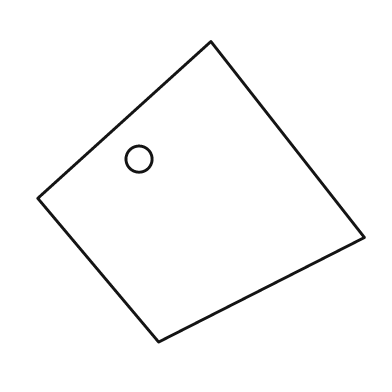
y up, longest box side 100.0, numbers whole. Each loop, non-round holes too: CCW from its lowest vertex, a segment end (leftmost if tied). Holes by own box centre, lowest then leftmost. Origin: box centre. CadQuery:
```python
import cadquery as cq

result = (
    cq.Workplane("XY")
    .moveTo(-13.0, -46.0)
    .lineTo(50.0, -14.0)
    .lineTo(3.0, 46.0)
    .lineTo(-50.0, -2.0)
    .close()
    .moveTo(-19.0, 10.0)
    .circle(4.0)
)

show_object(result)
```